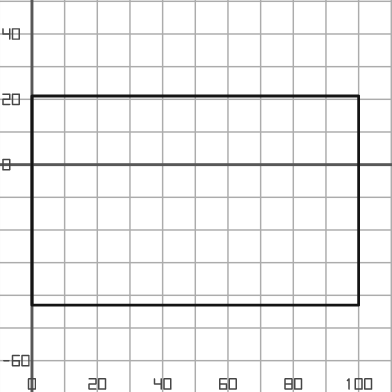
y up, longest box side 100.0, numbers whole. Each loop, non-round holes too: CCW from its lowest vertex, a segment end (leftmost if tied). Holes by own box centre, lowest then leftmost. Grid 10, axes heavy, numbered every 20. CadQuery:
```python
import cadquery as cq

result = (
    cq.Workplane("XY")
    .moveTo(0.0, -43.0)
    .lineTo(100.0, -43.0)
    .lineTo(100.0, 21.0)
    .lineTo(0.0, 21.0)
    .close()
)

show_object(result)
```